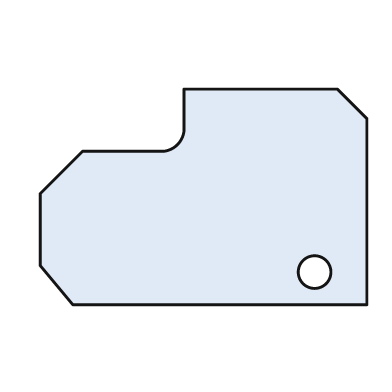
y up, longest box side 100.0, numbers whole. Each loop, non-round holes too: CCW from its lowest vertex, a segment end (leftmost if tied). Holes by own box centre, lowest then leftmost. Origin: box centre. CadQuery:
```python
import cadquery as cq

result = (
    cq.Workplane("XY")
    .moveTo(-40.0, -33.0)
    .lineTo(50.0, -33.0)
    .lineTo(50.0, 24.0)
    .lineTo(41.0, 33.0)
    .lineTo(-6.0, 33.0)
    .lineTo(-6.0, 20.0)
    .threePointArc((-8.0, 16.0), (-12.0, 14.0))
    .lineTo(-37.0, 14.0)
    .lineTo(-50.0, 1.0)
    .lineTo(-50.0, -21.0)
    .close()
    .moveTo(34.0, -23.0)
    .circle(5.0)
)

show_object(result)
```